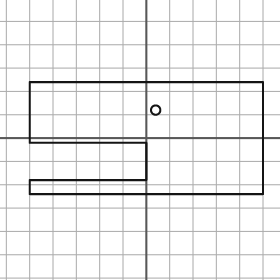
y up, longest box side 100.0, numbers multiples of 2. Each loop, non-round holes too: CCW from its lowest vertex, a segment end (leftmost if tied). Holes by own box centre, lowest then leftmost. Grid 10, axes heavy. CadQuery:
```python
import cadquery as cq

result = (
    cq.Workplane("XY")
    .moveTo(-50.0, -24.0)
    .lineTo(50.0, -24.0)
    .lineTo(50.0, 24.0)
    .lineTo(-50.0, 24.0)
    .lineTo(-50.0, -2.0)
    .lineTo(0.0, -2.0)
    .lineTo(0.0, -18.0)
    .lineTo(-50.0, -18.0)
    .close()
    .moveTo(4.0, 12.0)
    .circle(2.0)
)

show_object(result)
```